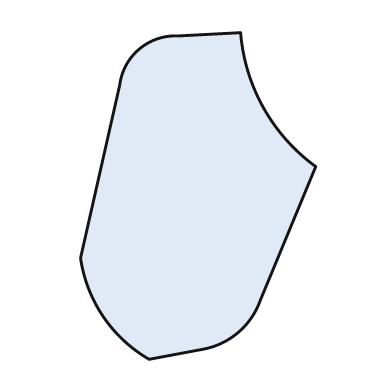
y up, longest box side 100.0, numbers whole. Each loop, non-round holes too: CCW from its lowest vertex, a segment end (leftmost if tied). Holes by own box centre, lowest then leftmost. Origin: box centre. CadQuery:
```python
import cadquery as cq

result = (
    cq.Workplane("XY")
    .moveTo(-15.0, -50.0)
    .lineTo(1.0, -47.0)
    .threePointArc((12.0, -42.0), (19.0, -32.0))
    .lineTo(36.0, 9.0)
    .threePointArc((20.0, 27.0), (13.0, 50.0))
    .lineTo(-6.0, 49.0)
    .threePointArc((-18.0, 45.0), (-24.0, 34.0))
    .lineTo(-36.0, -19.0)
    .threePointArc((-29.0, -37.0), (-15.0, -50.0))
    .close()
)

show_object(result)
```